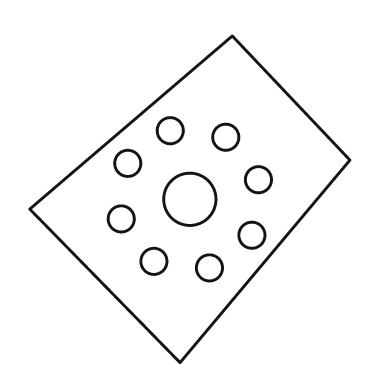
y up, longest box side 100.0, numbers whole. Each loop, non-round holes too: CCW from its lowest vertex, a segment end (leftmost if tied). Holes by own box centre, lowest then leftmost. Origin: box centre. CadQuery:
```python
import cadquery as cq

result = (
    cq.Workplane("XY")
    .moveTo(-3.0, -50.0)
    .lineTo(49.0, 12.0)
    .lineTo(13.0, 50.0)
    .lineTo(-49.0, -3.0)
    .close()
    .moveTo(6.0, -21.0)
    .circle(4.0)
    .moveTo(-11.0, -19.0)
    .circle(4.0)
    .moveTo(19.0, -11.0)
    .circle(4.0)
    .moveTo(-21.0, -6.0)
    .circle(4.0)
    .moveTo(0.0, 0.0)
    .circle(8.0)
    .moveTo(21.0, 6.0)
    .circle(4.0)
    .moveTo(-19.0, 11.0)
    .circle(4.0)
    .moveTo(11.0, 19.0)
    .circle(4.0)
    .moveTo(-6.0, 21.0)
    .circle(4.0)
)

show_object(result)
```